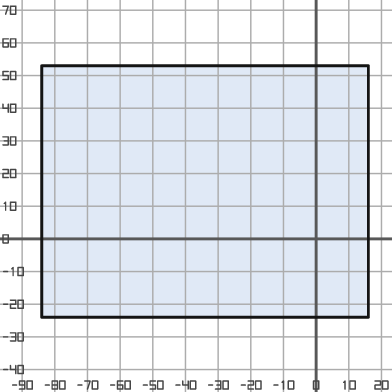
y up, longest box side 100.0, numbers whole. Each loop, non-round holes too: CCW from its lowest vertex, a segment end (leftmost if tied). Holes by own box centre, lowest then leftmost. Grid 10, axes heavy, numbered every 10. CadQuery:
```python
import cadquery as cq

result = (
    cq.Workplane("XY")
    .moveTo(-84.0, -24.0)
    .lineTo(16.0, -24.0)
    .lineTo(16.0, 53.0)
    .lineTo(-84.0, 53.0)
    .close()
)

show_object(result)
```